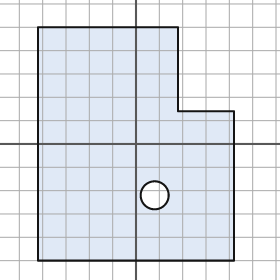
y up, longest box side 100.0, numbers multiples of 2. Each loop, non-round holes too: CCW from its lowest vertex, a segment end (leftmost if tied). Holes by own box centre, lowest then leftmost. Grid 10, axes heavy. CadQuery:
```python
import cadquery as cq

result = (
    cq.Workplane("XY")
    .moveTo(-42.0, -50.0)
    .lineTo(42.0, -50.0)
    .lineTo(42.0, 14.0)
    .lineTo(18.0, 14.0)
    .lineTo(18.0, 50.0)
    .lineTo(-42.0, 50.0)
    .close()
    .moveTo(8.0, -22.0)
    .circle(6.0)
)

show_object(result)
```